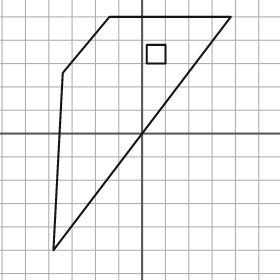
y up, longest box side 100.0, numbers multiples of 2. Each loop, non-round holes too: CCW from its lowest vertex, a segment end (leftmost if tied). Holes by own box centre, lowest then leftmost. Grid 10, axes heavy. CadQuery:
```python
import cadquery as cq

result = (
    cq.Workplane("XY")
    .moveTo(-38.0, -50.0)
    .lineTo(38.0, 50.0)
    .lineTo(-14.0, 50.0)
    .lineTo(-34.0, 26.0)
    .close()
    .moveTo(2.0, 30.0)
    .lineTo(10.0, 30.0)
    .lineTo(10.0, 38.0)
    .lineTo(2.0, 38.0)
    .close()
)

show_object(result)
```